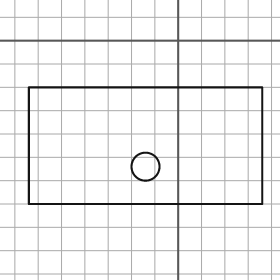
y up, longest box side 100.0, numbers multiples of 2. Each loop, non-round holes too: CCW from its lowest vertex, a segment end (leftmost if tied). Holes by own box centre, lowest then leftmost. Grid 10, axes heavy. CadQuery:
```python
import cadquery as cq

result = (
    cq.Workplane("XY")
    .moveTo(-64.0, -70.0)
    .lineTo(36.0, -70.0)
    .lineTo(36.0, -20.0)
    .lineTo(-64.0, -20.0)
    .close()
    .moveTo(-14.0, -54.0)
    .circle(6.0)
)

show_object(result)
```